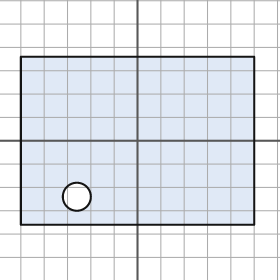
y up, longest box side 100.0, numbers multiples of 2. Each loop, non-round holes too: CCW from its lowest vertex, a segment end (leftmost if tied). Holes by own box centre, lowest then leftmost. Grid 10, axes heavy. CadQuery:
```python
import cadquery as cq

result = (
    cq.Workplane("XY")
    .moveTo(-50.0, -36.0)
    .lineTo(50.0, -36.0)
    .lineTo(50.0, 36.0)
    .lineTo(-50.0, 36.0)
    .close()
    .moveTo(-26.0, -24.0)
    .circle(6.0)
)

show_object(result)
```